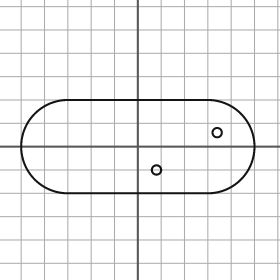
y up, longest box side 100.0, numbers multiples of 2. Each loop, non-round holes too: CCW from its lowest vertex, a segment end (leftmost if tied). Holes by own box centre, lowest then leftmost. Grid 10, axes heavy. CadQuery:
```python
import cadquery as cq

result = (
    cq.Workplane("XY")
    .moveTo(-30.0, -20.0)
    .lineTo(30.0, -20.0)
    .threePointArc((50.0, 0.0), (30.0, 20.0))
    .lineTo(-30.0, 20.0)
    .threePointArc((-50.0, 0.0), (-30.0, -20.0))
    .close()
    .moveTo(8.0, -10.0)
    .circle(2.0)
    .moveTo(34.0, 6.0)
    .circle(2.0)
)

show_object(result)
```